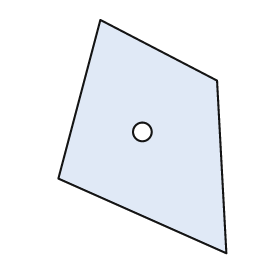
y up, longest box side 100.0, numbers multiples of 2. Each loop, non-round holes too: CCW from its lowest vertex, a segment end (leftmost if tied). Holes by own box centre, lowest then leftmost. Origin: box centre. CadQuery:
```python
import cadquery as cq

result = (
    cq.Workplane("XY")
    .moveTo(36.0, -50.0)
    .lineTo(32.0, 24.0)
    .lineTo(-18.0, 50.0)
    .lineTo(-36.0, -18.0)
    .close()
    .moveTo(0.0, 2.0)
    .circle(4.0)
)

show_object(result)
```